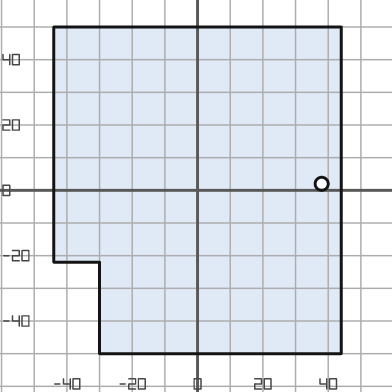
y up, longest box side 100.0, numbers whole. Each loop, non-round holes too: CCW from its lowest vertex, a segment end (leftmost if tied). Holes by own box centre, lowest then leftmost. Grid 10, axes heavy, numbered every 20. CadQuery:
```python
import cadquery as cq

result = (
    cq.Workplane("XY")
    .moveTo(-30.0, -50.0)
    .lineTo(44.0, -50.0)
    .lineTo(44.0, 50.0)
    .lineTo(-44.0, 50.0)
    .lineTo(-44.0, -22.0)
    .lineTo(-30.0, -22.0)
    .close()
    .moveTo(38.0, 2.0)
    .circle(2.0)
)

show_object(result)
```